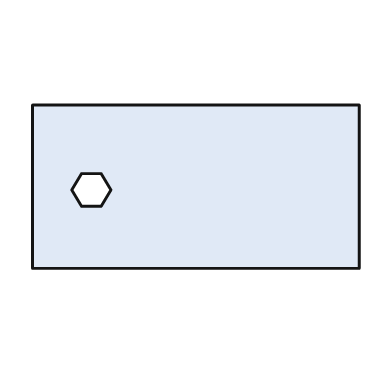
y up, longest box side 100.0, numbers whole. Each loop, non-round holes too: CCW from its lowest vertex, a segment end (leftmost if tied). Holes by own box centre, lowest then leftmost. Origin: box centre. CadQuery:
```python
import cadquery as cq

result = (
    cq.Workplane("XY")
    .moveTo(-50.0, -25.0)
    .lineTo(50.0, -25.0)
    .lineTo(50.0, 25.0)
    .lineTo(-50.0, 25.0)
    .close()
    .moveTo(-35.0, -6.0)
    .lineTo(-29.0, -6.0)
    .lineTo(-26.0, -1.0)
    .lineTo(-29.0, 4.0)
    .lineTo(-35.0, 4.0)
    .lineTo(-38.0, -1.0)
    .close()
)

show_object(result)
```